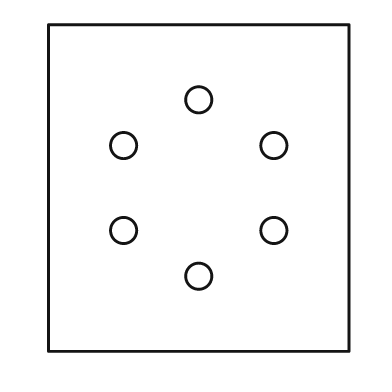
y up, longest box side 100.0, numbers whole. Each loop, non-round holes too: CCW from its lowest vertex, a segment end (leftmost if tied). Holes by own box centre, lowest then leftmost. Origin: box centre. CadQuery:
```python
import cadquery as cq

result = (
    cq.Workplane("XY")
    .moveTo(-46.0, -50.0)
    .lineTo(46.0, -50.0)
    .lineTo(46.0, 50.0)
    .lineTo(-46.0, 50.0)
    .close()
    .moveTo(0.0, -27.0)
    .circle(4.0)
    .moveTo(-23.0, -13.0)
    .circle(4.0)
    .moveTo(23.0, -13.0)
    .circle(4.0)
    .moveTo(-23.0, 13.0)
    .circle(4.0)
    .moveTo(23.0, 13.0)
    .circle(4.0)
    .moveTo(0.0, 27.0)
    .circle(4.0)
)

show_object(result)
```